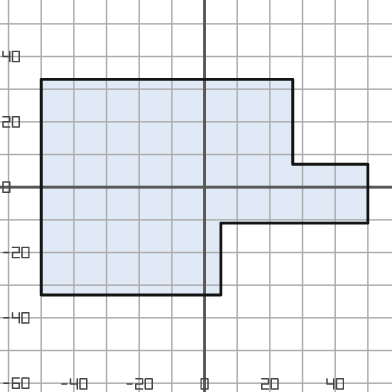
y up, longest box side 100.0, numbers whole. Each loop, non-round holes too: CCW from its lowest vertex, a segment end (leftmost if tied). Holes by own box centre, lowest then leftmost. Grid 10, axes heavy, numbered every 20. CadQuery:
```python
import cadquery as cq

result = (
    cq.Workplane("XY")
    .moveTo(-50.0, -33.0)
    .lineTo(5.0, -33.0)
    .lineTo(5.0, -11.0)
    .lineTo(50.0, -11.0)
    .lineTo(50.0, 7.0)
    .lineTo(27.0, 7.0)
    .lineTo(27.0, 33.0)
    .lineTo(-50.0, 33.0)
    .close()
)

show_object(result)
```